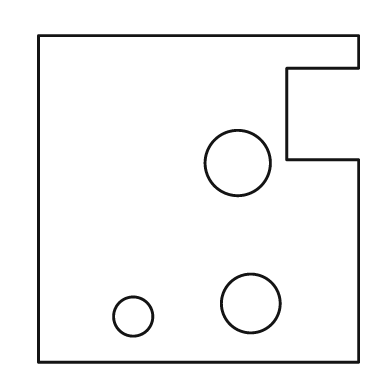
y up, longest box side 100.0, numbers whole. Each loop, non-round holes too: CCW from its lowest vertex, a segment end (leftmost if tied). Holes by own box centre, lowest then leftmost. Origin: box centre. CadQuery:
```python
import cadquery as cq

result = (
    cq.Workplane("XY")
    .moveTo(-49.0, -50.0)
    .lineTo(49.0, -50.0)
    .lineTo(49.0, 12.0)
    .lineTo(27.0, 12.0)
    .lineTo(27.0, 40.0)
    .lineTo(49.0, 40.0)
    .lineTo(49.0, 50.0)
    .lineTo(-49.0, 50.0)
    .close()
    .moveTo(-20.0, -36.0)
    .circle(6.0)
    .moveTo(16.0, -32.0)
    .circle(9.0)
    .moveTo(12.0, 11.0)
    .circle(10.0)
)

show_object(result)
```